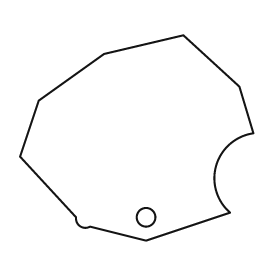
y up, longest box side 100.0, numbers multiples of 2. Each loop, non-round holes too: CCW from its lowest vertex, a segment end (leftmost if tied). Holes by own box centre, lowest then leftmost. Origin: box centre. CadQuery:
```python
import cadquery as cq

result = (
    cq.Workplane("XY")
    .moveTo(4.0, -44.0)
    .lineTo(40.0, -32.0)
    .threePointArc((34.0, -12.0), (50.0, 2.0))
    .lineTo(44.0, 22.0)
    .lineTo(20.0, 44.0)
    .lineTo(-14.0, 36.0)
    .lineTo(-42.0, 16.0)
    .lineTo(-50.0, -8.0)
    .lineTo(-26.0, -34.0)
    .threePointArc((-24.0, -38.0), (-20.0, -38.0))
    .close()
    .moveTo(4.0, -34.0)
    .circle(4.0)
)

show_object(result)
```